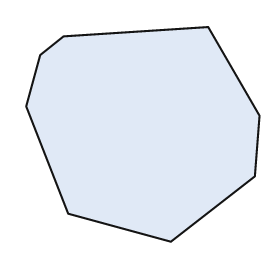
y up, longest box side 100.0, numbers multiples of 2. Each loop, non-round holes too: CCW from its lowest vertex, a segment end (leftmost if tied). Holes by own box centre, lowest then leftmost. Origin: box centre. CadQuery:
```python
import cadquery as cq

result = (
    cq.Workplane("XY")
    .moveTo(12.0, -46.0)
    .lineTo(48.0, -18.0)
    .lineTo(50.0, 8.0)
    .lineTo(28.0, 46.0)
    .lineTo(-34.0, 42.0)
    .lineTo(-44.0, 34.0)
    .lineTo(-50.0, 12.0)
    .lineTo(-32.0, -34.0)
    .close()
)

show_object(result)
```